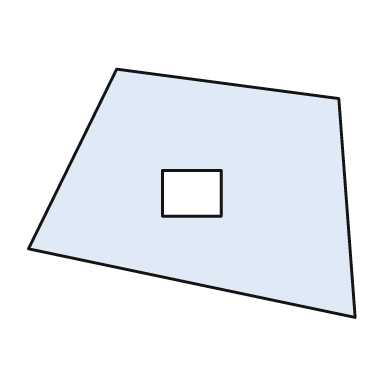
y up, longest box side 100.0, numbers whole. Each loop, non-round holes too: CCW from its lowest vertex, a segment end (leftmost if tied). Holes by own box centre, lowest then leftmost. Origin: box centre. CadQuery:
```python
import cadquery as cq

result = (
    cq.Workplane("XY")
    .moveTo(50.0, -38.0)
    .lineTo(45.0, 29.0)
    .lineTo(-23.0, 38.0)
    .lineTo(-50.0, -17.0)
    .close()
    .moveTo(-9.0, -7.0)
    .lineTo(9.0, -7.0)
    .lineTo(9.0, 7.0)
    .lineTo(-9.0, 7.0)
    .close()
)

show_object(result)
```